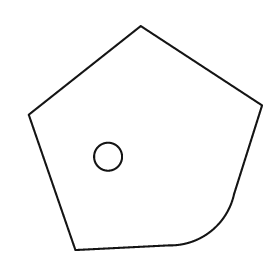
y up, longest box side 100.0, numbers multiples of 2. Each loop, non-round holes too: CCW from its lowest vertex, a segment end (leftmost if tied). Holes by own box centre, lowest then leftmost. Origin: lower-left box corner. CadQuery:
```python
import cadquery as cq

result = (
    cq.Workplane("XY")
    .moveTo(20.0, 0.0)
    .lineTo(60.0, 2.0)
    .threePointArc((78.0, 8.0), (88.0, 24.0))
    .lineTo(100.0, 62.0)
    .lineTo(48.0, 96.0)
    .lineTo(0.0, 58.0)
    .close()
    .moveTo(34.0, 40.0)
    .circle(6.0)
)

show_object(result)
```